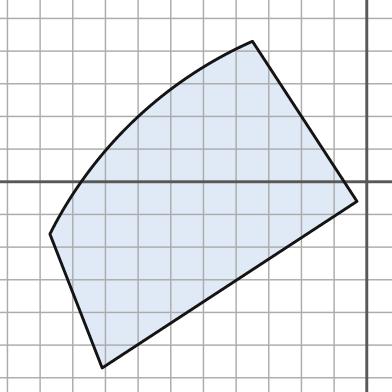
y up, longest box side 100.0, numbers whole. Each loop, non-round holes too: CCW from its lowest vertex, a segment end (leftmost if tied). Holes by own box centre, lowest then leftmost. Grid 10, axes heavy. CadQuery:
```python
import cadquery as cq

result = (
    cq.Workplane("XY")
    .moveTo(-81.0, -57.0)
    .lineTo(-3.0, -6.0)
    .lineTo(-35.0, 43.0)
    .threePointArc((-71.0, 19.0), (-97.0, -16.0))
    .close()
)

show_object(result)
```